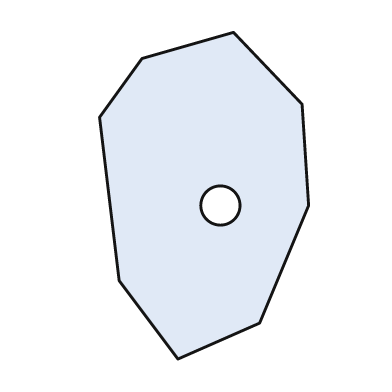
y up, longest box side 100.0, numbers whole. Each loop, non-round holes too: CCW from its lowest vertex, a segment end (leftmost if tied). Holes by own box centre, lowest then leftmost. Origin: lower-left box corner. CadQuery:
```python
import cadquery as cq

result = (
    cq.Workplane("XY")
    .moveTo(24.0, 0.0)
    .lineTo(49.0, 11.0)
    .lineTo(64.0, 47.0)
    .lineTo(62.0, 78.0)
    .lineTo(41.0, 100.0)
    .lineTo(13.0, 92.0)
    .lineTo(0.0, 74.0)
    .lineTo(6.0, 24.0)
    .close()
    .moveTo(37.0, 47.0)
    .circle(6.0)
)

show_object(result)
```